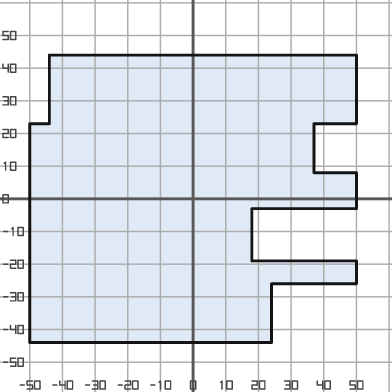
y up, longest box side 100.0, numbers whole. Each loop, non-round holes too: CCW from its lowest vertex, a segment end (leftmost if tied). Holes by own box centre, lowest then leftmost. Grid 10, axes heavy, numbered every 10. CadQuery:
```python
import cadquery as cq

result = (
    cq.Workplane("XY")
    .moveTo(-50.0, -44.0)
    .lineTo(24.0, -44.0)
    .lineTo(24.0, -26.0)
    .lineTo(50.0, -26.0)
    .lineTo(50.0, -19.0)
    .lineTo(18.0, -19.0)
    .lineTo(18.0, -3.0)
    .lineTo(50.0, -3.0)
    .lineTo(50.0, 8.0)
    .lineTo(37.0, 8.0)
    .lineTo(37.0, 23.0)
    .lineTo(50.0, 23.0)
    .lineTo(50.0, 44.0)
    .lineTo(-44.0, 44.0)
    .lineTo(-44.0, 23.0)
    .lineTo(-50.0, 23.0)
    .close()
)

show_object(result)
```